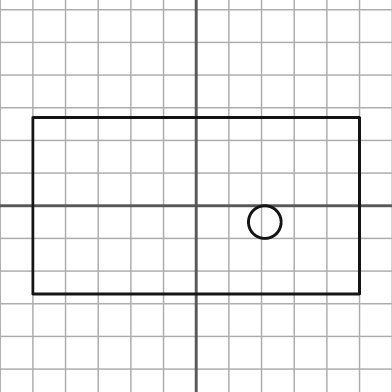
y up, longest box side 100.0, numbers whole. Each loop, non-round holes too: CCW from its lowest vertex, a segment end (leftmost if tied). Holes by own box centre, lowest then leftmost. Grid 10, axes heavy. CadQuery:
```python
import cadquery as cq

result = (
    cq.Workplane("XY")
    .moveTo(-50.0, -27.0)
    .lineTo(50.0, -27.0)
    .lineTo(50.0, 27.0)
    .lineTo(-50.0, 27.0)
    .close()
    .moveTo(21.0, -5.0)
    .circle(5.0)
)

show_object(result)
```